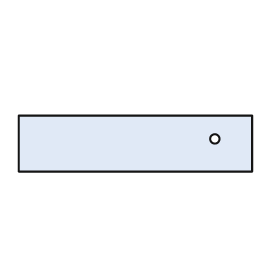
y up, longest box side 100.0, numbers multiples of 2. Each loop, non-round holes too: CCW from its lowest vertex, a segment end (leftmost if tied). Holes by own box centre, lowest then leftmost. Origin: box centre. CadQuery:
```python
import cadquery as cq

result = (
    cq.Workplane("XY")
    .moveTo(-50.0, -12.0)
    .lineTo(50.0, -12.0)
    .lineTo(50.0, 12.0)
    .lineTo(-50.0, 12.0)
    .close()
    .moveTo(34.0, 2.0)
    .circle(2.0)
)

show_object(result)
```